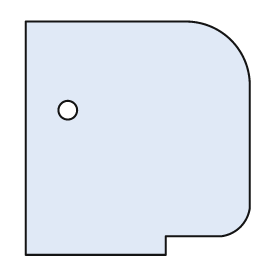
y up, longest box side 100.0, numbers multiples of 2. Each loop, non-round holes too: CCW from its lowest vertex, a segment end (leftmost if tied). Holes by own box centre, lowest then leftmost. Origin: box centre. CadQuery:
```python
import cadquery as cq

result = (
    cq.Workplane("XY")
    .moveTo(-48.0, -50.0)
    .lineTo(12.0, -50.0)
    .lineTo(12.0, -42.0)
    .lineTo(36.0, -42.0)
    .threePointArc((44.0, -38.0), (48.0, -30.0))
    .lineTo(48.0, 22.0)
    .threePointArc((40.0, 42.0), (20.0, 50.0))
    .lineTo(-48.0, 50.0)
    .close()
    .moveTo(-30.0, 12.0)
    .circle(4.0)
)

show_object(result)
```